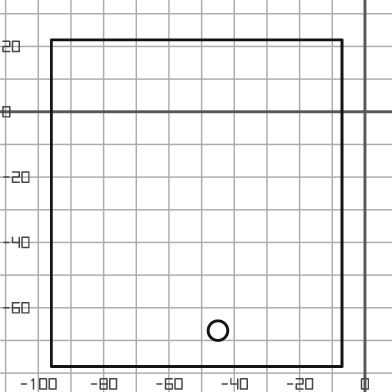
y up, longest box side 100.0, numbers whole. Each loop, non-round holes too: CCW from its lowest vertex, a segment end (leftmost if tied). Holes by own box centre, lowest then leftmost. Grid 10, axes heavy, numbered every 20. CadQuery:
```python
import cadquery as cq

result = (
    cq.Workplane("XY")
    .moveTo(-96.0, -78.0)
    .lineTo(-7.0, -78.0)
    .lineTo(-7.0, 22.0)
    .lineTo(-96.0, 22.0)
    .close()
    .moveTo(-45.0, -67.0)
    .circle(3.0)
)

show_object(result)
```